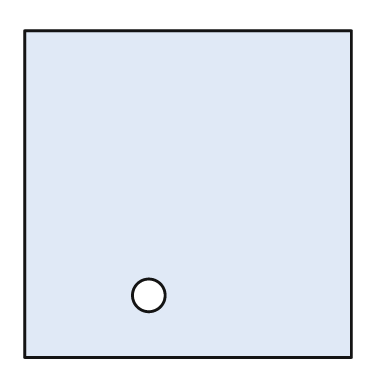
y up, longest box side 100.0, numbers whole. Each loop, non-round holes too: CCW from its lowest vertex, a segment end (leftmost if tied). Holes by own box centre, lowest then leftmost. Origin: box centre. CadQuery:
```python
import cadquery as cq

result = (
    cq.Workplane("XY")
    .moveTo(-50.0, -50.0)
    .lineTo(50.0, -50.0)
    .lineTo(50.0, 50.0)
    .lineTo(-50.0, 50.0)
    .close()
    .moveTo(-12.0, -31.0)
    .circle(5.0)
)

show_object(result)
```